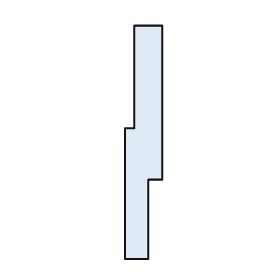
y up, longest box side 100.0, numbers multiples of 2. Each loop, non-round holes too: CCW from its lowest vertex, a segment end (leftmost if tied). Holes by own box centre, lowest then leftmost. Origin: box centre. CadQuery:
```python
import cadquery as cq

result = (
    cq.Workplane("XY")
    .moveTo(-8.0, -50.0)
    .lineTo(2.0, -50.0)
    .lineTo(2.0, -16.0)
    .lineTo(8.0, -16.0)
    .lineTo(8.0, 50.0)
    .lineTo(-4.0, 50.0)
    .lineTo(-4.0, 6.0)
    .lineTo(-8.0, 6.0)
    .close()
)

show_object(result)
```